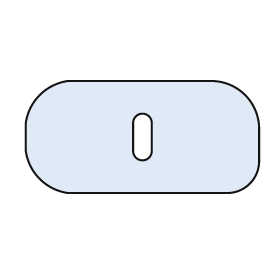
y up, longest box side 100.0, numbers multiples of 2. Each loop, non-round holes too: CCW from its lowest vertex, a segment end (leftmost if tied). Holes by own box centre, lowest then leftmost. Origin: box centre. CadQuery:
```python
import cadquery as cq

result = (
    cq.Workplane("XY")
    .moveTo(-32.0, -24.0)
    .lineTo(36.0, -24.0)
    .threePointArc((46.0, -20.0), (50.0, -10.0))
    .lineTo(50.0, 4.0)
    .threePointArc((44.0, 18.0), (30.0, 24.0))
    .lineTo(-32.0, 24.0)
    .threePointArc((-44.0, 18.0), (-50.0, 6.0))
    .lineTo(-50.0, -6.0)
    .threePointArc((-44.0, -18.0), (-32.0, -24.0))
    .close()
    .moveTo(-4.0, -6.0)
    .threePointArc((0.0, -10.0), (4.0, -6.0))
    .lineTo(4.0, 6.0)
    .threePointArc((0.0, 10.0), (-4.0, 6.0))
    .close()
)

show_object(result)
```